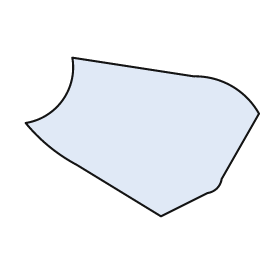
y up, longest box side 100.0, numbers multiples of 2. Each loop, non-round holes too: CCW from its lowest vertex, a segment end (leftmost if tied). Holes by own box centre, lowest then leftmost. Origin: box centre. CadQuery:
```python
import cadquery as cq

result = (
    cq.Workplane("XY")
    .moveTo(8.0, -34.0)
    .lineTo(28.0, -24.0)
    .threePointArc((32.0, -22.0), (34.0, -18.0))
    .lineTo(50.0, 10.0)
    .threePointArc((38.0, 22.0), (22.0, 26.0))
    .lineTo(-30.0, 34.0)
    .threePointArc((-34.0, 16.0), (-50.0, 6.0))
    .threePointArc((-40.0, -4.0), (-28.0, -12.0))
    .close()
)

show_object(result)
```